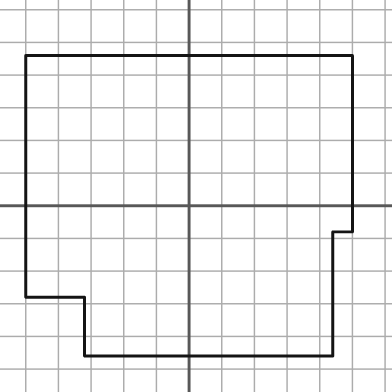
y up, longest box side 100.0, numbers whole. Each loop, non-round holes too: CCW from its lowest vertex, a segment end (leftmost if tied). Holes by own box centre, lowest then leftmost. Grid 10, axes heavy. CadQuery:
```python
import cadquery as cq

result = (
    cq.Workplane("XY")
    .moveTo(-32.0, -46.0)
    .lineTo(44.0, -46.0)
    .lineTo(44.0, -8.0)
    .lineTo(50.0, -8.0)
    .lineTo(50.0, 46.0)
    .lineTo(-50.0, 46.0)
    .lineTo(-50.0, -28.0)
    .lineTo(-32.0, -28.0)
    .close()
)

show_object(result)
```